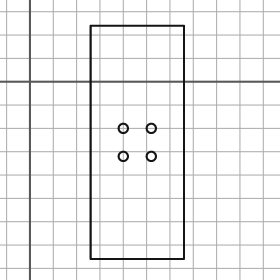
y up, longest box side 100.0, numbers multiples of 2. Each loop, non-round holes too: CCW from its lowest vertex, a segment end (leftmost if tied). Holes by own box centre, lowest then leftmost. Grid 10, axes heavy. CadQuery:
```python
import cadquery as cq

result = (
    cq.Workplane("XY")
    .moveTo(26.0, -76.0)
    .lineTo(66.0, -76.0)
    .lineTo(66.0, 24.0)
    .lineTo(26.0, 24.0)
    .close()
    .moveTo(40.0, -32.0)
    .circle(2.0)
    .moveTo(52.0, -32.0)
    .circle(2.0)
    .moveTo(40.0, -20.0)
    .circle(2.0)
    .moveTo(52.0, -20.0)
    .circle(2.0)
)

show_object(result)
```